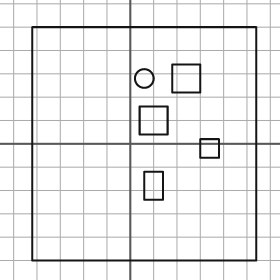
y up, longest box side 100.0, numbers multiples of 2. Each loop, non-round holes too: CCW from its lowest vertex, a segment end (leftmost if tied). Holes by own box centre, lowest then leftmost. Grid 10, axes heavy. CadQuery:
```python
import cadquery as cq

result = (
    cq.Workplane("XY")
    .moveTo(-42.0, -50.0)
    .lineTo(54.0, -50.0)
    .lineTo(54.0, 50.0)
    .lineTo(-42.0, 50.0)
    .close()
    .moveTo(6.0, -24.0)
    .lineTo(14.0, -24.0)
    .lineTo(14.0, -12.0)
    .lineTo(6.0, -12.0)
    .close()
    .moveTo(30.0, -6.0)
    .lineTo(38.0, -6.0)
    .lineTo(38.0, 2.0)
    .lineTo(30.0, 2.0)
    .close()
    .moveTo(4.0, 4.0)
    .lineTo(16.0, 4.0)
    .lineTo(16.0, 16.0)
    .lineTo(4.0, 16.0)
    .close()
    .moveTo(6.0, 28.0)
    .circle(4.0)
    .moveTo(18.0, 22.0)
    .lineTo(30.0, 22.0)
    .lineTo(30.0, 34.0)
    .lineTo(18.0, 34.0)
    .close()
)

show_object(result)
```